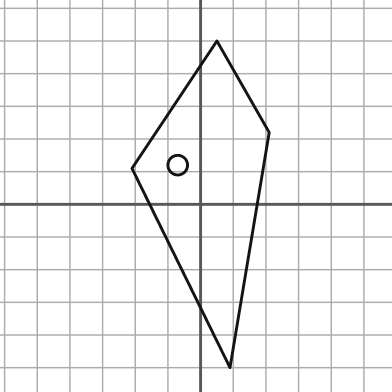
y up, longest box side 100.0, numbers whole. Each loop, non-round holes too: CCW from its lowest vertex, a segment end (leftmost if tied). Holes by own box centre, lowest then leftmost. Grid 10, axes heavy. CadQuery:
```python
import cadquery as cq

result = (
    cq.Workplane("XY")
    .moveTo(9.0, -50.0)
    .lineTo(21.0, 22.0)
    .lineTo(5.0, 50.0)
    .lineTo(-21.0, 11.0)
    .close()
    .moveTo(-7.0, 12.0)
    .circle(3.0)
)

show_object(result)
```